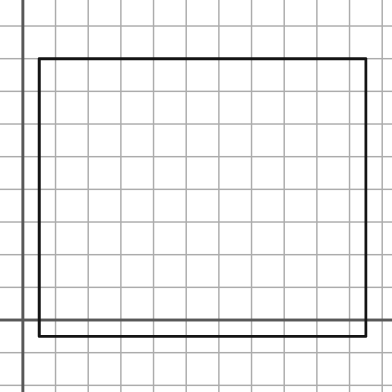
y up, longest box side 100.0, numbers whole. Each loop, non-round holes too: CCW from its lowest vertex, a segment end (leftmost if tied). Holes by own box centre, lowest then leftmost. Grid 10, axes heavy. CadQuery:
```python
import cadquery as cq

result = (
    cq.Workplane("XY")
    .moveTo(5.0, -5.0)
    .lineTo(105.0, -5.0)
    .lineTo(105.0, 80.0)
    .lineTo(5.0, 80.0)
    .close()
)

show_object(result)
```